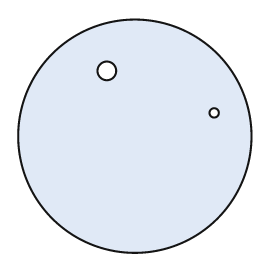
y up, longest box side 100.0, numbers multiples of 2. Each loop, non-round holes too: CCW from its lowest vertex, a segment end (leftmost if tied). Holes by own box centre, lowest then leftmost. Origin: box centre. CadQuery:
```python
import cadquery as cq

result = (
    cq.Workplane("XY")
    .moveTo(0.0, 0.0)
    .circle(50.0)
    .moveTo(34.0, 10.0)
    .circle(2.0)
    .moveTo(-12.0, 28.0)
    .circle(4.0)
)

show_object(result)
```